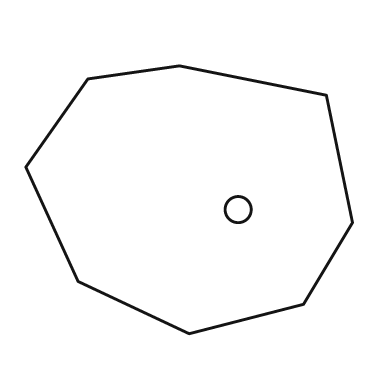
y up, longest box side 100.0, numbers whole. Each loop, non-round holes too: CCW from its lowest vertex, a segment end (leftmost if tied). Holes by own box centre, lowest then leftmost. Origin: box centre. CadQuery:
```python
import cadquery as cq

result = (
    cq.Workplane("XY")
    .moveTo(0.0, -41.0)
    .lineTo(35.0, -32.0)
    .lineTo(50.0, -7.0)
    .lineTo(42.0, 32.0)
    .lineTo(-3.0, 41.0)
    .lineTo(-31.0, 37.0)
    .lineTo(-50.0, 10.0)
    .lineTo(-34.0, -25.0)
    .close()
    .moveTo(15.0, -3.0)
    .circle(4.0)
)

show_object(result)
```